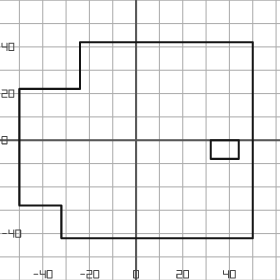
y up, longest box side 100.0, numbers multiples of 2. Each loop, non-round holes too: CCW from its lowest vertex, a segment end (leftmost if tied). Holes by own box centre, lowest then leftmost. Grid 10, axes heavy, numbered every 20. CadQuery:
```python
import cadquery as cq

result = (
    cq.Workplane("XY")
    .moveTo(-32.0, -42.0)
    .lineTo(50.0, -42.0)
    .lineTo(50.0, 42.0)
    .lineTo(-24.0, 42.0)
    .lineTo(-24.0, 22.0)
    .lineTo(-50.0, 22.0)
    .lineTo(-50.0, -28.0)
    .lineTo(-32.0, -28.0)
    .close()
    .moveTo(32.0, -8.0)
    .lineTo(44.0, -8.0)
    .lineTo(44.0, 0.0)
    .lineTo(32.0, 0.0)
    .close()
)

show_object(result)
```